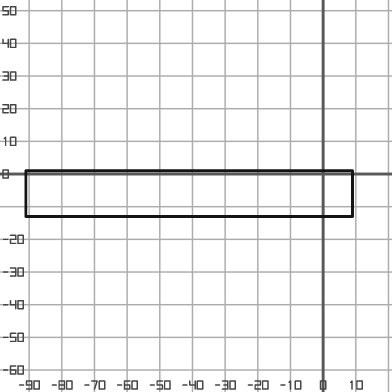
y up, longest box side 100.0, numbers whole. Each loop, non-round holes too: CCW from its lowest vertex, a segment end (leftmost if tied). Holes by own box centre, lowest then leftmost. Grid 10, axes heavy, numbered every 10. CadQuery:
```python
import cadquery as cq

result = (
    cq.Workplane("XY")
    .moveTo(-91.0, -13.0)
    .lineTo(9.0, -13.0)
    .lineTo(9.0, 1.0)
    .lineTo(-91.0, 1.0)
    .close()
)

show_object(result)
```